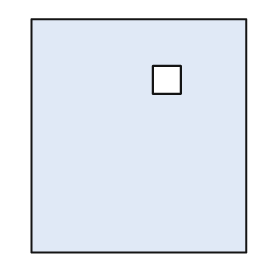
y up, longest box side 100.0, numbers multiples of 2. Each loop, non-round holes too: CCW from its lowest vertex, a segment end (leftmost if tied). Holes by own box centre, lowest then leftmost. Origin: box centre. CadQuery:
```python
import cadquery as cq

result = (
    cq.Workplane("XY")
    .moveTo(-46.0, -50.0)
    .lineTo(46.0, -50.0)
    .lineTo(46.0, 50.0)
    .lineTo(-46.0, 50.0)
    .close()
    .moveTo(6.0, 18.0)
    .lineTo(18.0, 18.0)
    .lineTo(18.0, 30.0)
    .lineTo(6.0, 30.0)
    .close()
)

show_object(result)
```